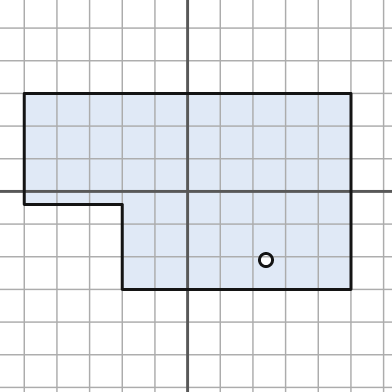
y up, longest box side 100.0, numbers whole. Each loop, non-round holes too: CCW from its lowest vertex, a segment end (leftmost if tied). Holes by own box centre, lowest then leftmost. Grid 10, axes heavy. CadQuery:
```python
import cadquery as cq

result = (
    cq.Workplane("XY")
    .moveTo(-20.0, -30.0)
    .lineTo(50.0, -30.0)
    .lineTo(50.0, 30.0)
    .lineTo(-50.0, 30.0)
    .lineTo(-50.0, -4.0)
    .lineTo(-20.0, -4.0)
    .close()
    .moveTo(24.0, -21.0)
    .circle(2.0)
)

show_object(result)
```